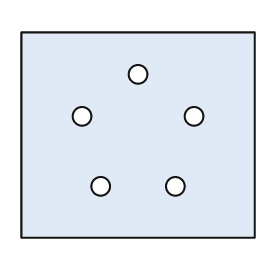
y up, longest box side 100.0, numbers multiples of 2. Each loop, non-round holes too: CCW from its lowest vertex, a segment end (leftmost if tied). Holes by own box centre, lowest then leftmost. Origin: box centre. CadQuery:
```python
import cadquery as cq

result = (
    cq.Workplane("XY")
    .moveTo(-50.0, -44.0)
    .lineTo(50.0, -44.0)
    .lineTo(50.0, 44.0)
    .lineTo(-50.0, 44.0)
    .close()
    .moveTo(-16.0, -22.0)
    .circle(4.0)
    .moveTo(16.0, -22.0)
    .circle(4.0)
    .moveTo(-24.0, 8.0)
    .circle(4.0)
    .moveTo(24.0, 8.0)
    .circle(4.0)
    .moveTo(0.0, 26.0)
    .circle(4.0)
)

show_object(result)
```